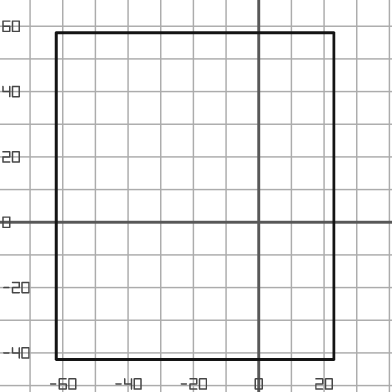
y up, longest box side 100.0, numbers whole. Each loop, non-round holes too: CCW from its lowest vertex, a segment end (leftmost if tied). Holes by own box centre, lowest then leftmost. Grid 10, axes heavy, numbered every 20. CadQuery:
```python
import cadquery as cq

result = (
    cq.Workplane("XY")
    .moveTo(-62.0, -42.0)
    .lineTo(23.0, -42.0)
    .lineTo(23.0, 58.0)
    .lineTo(-62.0, 58.0)
    .close()
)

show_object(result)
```